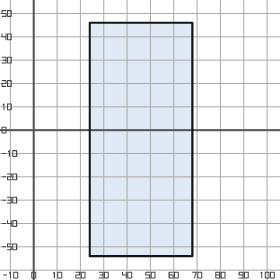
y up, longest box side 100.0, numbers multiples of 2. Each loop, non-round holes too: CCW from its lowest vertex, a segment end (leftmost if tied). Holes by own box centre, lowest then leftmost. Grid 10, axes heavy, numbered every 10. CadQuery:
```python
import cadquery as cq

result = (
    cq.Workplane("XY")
    .moveTo(24.0, -54.0)
    .lineTo(68.0, -54.0)
    .lineTo(68.0, 46.0)
    .lineTo(24.0, 46.0)
    .close()
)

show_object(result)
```